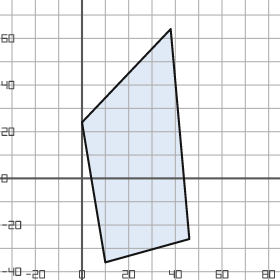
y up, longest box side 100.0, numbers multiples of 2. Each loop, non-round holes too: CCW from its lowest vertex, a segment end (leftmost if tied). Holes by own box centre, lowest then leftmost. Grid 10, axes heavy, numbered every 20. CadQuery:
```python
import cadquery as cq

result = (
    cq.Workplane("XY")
    .moveTo(10.0, -36.0)
    .lineTo(46.0, -26.0)
    .lineTo(38.0, 64.0)
    .lineTo(0.0, 24.0)
    .close()
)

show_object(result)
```